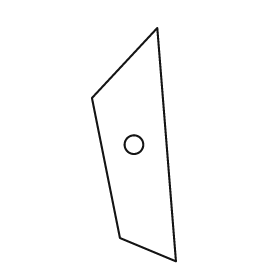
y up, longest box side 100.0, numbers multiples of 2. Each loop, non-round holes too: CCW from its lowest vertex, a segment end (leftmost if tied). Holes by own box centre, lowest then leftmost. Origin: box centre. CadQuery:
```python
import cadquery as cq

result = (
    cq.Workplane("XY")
    .moveTo(18.0, -50.0)
    .lineTo(10.0, 50.0)
    .lineTo(-18.0, 20.0)
    .lineTo(-6.0, -40.0)
    .close()
    .moveTo(0.0, 0.0)
    .circle(4.0)
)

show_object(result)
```